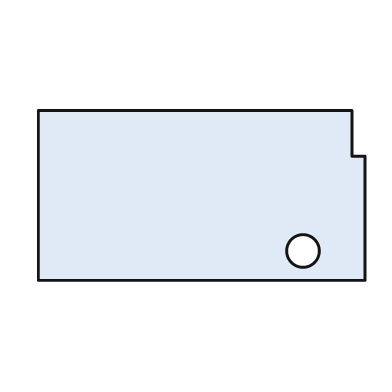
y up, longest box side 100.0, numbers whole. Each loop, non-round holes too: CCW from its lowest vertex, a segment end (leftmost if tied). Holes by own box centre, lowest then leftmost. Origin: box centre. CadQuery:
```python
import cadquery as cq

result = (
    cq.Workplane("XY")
    .moveTo(-50.0, -26.0)
    .lineTo(50.0, -26.0)
    .lineTo(50.0, 12.0)
    .lineTo(46.0, 12.0)
    .lineTo(46.0, 26.0)
    .lineTo(-50.0, 26.0)
    .close()
    .moveTo(31.0, -17.0)
    .circle(5.0)
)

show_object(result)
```